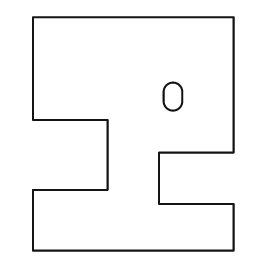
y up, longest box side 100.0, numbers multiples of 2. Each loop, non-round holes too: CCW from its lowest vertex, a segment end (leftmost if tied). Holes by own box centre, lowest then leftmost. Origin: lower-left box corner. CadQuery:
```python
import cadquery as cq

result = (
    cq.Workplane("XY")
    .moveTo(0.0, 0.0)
    .lineTo(86.0, 0.0)
    .lineTo(86.0, 20.0)
    .lineTo(54.0, 20.0)
    .lineTo(54.0, 42.0)
    .lineTo(86.0, 42.0)
    .lineTo(86.0, 100.0)
    .lineTo(0.0, 100.0)
    .lineTo(0.0, 56.0)
    .lineTo(32.0, 56.0)
    .lineTo(32.0, 26.0)
    .lineTo(0.0, 26.0)
    .close()
    .moveTo(56.0, 64.0)
    .threePointArc((60.0, 60.0), (64.0, 64.0))
    .lineTo(64.0, 68.0)
    .threePointArc((60.0, 72.0), (56.0, 68.0))
    .close()
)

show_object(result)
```